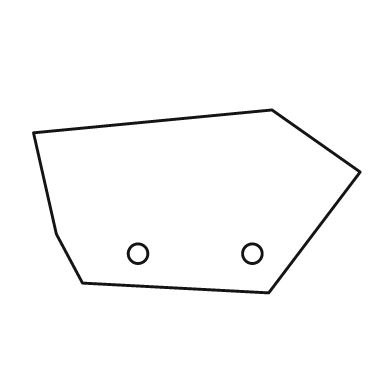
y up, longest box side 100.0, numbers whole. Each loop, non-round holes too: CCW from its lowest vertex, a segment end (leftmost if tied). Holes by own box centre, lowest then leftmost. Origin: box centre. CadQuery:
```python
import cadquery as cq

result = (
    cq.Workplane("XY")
    .moveTo(22.0, -28.0)
    .lineTo(50.0, 9.0)
    .lineTo(23.0, 28.0)
    .lineTo(-50.0, 21.0)
    .lineTo(-43.0, -10.0)
    .lineTo(-35.0, -25.0)
    .close()
    .moveTo(-18.0, -16.0)
    .circle(3.0)
    .moveTo(17.0, -16.0)
    .circle(3.0)
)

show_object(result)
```